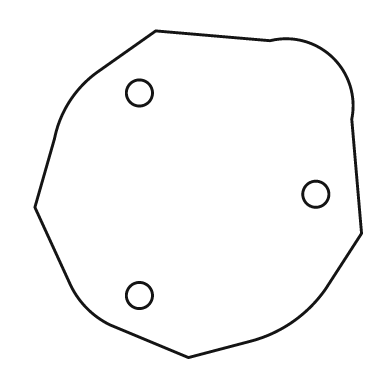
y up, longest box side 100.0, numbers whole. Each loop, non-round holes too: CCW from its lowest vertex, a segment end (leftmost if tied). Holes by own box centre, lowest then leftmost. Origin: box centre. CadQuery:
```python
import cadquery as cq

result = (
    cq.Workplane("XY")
    .moveTo(-3.0, -50.0)
    .lineTo(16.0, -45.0)
    .threePointArc((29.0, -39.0), (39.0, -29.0))
    .lineTo(50.0, -12.0)
    .lineTo(47.0, 23.0)
    .threePointArc((41.0, 42.0), (22.0, 47.0))
    .lineTo(-13.0, 50.0)
    .lineTo(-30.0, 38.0)
    .threePointArc((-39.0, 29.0), (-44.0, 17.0))
    .lineTo(-50.0, -4.0)
    .lineTo(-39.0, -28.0)
    .threePointArc((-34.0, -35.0), (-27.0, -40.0))
    .close()
    .moveTo(-18.0, -31.0)
    .circle(4.0)
    .moveTo(36.0, 0.0)
    .circle(4.0)
    .moveTo(-18.0, 31.0)
    .circle(4.0)
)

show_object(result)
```